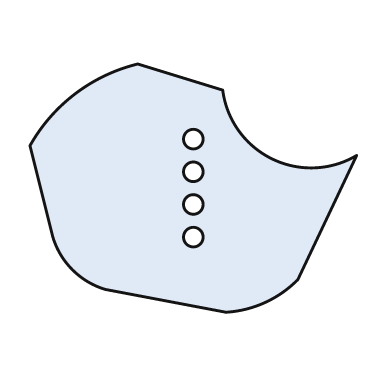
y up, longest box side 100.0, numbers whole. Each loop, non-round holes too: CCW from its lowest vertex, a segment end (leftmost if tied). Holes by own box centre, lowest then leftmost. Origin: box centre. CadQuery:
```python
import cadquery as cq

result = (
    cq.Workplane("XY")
    .moveTo(10.0, -38.0)
    .threePointArc((22.0, -35.0), (32.0, -28.0))
    .lineTo(50.0, 10.0)
    .threePointArc((24.0, 9.0), (9.0, 30.0))
    .lineTo(-17.0, 38.0)
    .threePointArc((-36.0, 29.0), (-50.0, 13.0))
    .lineTo(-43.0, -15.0)
    .threePointArc((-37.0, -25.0), (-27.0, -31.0))
    .close()
    .moveTo(0.0, -15.0)
    .circle(3.0)
    .moveTo(0.0, -5.0)
    .circle(3.0)
    .moveTo(0.0, 5.0)
    .circle(3.0)
    .moveTo(0.0, 15.0)
    .circle(3.0)
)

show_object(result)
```